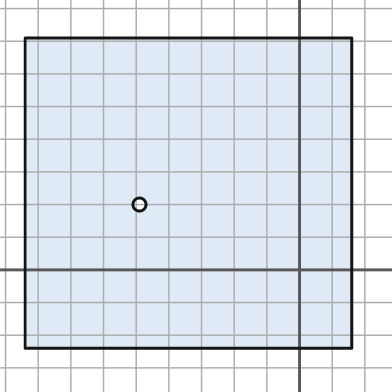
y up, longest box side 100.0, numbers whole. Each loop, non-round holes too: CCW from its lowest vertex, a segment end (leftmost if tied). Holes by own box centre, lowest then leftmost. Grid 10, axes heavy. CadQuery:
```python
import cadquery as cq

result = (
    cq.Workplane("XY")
    .moveTo(-84.0, -24.0)
    .lineTo(16.0, -24.0)
    .lineTo(16.0, 71.0)
    .lineTo(-84.0, 71.0)
    .close()
    .moveTo(-49.0, 20.0)
    .circle(2.0)
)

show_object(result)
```